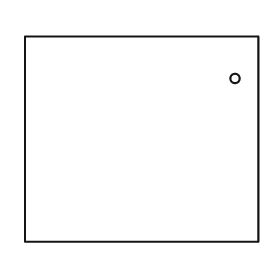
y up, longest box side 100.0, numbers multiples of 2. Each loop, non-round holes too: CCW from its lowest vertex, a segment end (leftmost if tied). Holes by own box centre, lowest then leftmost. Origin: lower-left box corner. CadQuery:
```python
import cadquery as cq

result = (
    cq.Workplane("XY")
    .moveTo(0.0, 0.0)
    .lineTo(100.0, 0.0)
    .lineTo(100.0, 88.0)
    .lineTo(0.0, 88.0)
    .close()
    .moveTo(90.0, 70.0)
    .circle(2.0)
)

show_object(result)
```